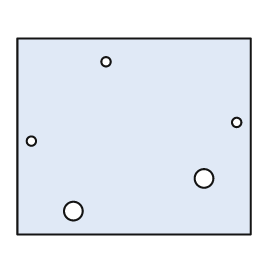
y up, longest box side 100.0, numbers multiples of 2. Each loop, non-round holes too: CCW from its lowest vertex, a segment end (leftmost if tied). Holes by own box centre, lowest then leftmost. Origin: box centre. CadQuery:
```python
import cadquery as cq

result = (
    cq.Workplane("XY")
    .moveTo(-50.0, -42.0)
    .lineTo(50.0, -42.0)
    .lineTo(50.0, 42.0)
    .lineTo(-50.0, 42.0)
    .close()
    .moveTo(-26.0, -32.0)
    .circle(4.0)
    .moveTo(30.0, -18.0)
    .circle(4.0)
    .moveTo(-44.0, -2.0)
    .circle(2.0)
    .moveTo(44.0, 6.0)
    .circle(2.0)
    .moveTo(-12.0, 32.0)
    .circle(2.0)
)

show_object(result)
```